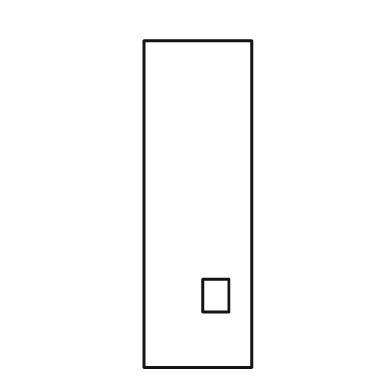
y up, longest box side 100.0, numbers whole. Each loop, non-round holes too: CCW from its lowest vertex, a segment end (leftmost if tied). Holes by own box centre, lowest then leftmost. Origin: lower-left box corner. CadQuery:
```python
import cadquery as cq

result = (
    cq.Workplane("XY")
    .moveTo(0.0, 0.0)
    .lineTo(33.0, 0.0)
    .lineTo(33.0, 100.0)
    .lineTo(0.0, 100.0)
    .close()
    .moveTo(18.0, 17.0)
    .lineTo(26.0, 17.0)
    .lineTo(26.0, 27.0)
    .lineTo(18.0, 27.0)
    .close()
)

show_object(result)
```